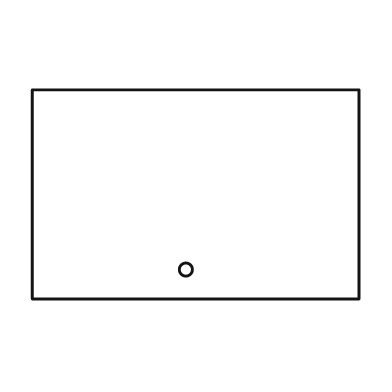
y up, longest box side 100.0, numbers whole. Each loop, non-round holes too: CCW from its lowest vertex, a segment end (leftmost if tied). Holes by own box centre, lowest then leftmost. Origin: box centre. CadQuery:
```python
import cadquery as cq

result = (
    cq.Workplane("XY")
    .moveTo(-50.0, -32.0)
    .lineTo(50.0, -32.0)
    .lineTo(50.0, 32.0)
    .lineTo(-50.0, 32.0)
    .close()
    .moveTo(-3.0, -23.0)
    .circle(2.0)
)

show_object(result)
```